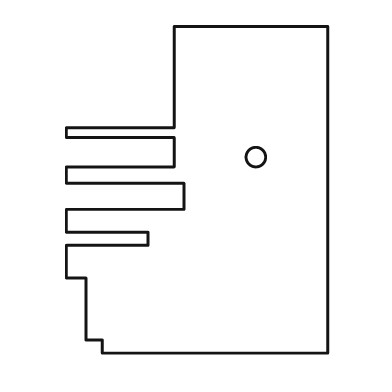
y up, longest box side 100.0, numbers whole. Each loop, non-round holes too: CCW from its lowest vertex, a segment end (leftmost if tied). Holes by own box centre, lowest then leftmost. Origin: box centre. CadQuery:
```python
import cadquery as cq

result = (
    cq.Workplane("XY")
    .moveTo(-29.0, -50.0)
    .lineTo(40.0, -50.0)
    .lineTo(40.0, 50.0)
    .lineTo(-7.0, 50.0)
    .lineTo(-7.0, 19.0)
    .lineTo(-40.0, 19.0)
    .lineTo(-40.0, 16.0)
    .lineTo(-7.0, 16.0)
    .lineTo(-7.0, 7.0)
    .lineTo(-40.0, 7.0)
    .lineTo(-40.0, 2.0)
    .lineTo(-4.0, 2.0)
    .lineTo(-4.0, -6.0)
    .lineTo(-40.0, -6.0)
    .lineTo(-40.0, -13.0)
    .lineTo(-15.0, -13.0)
    .lineTo(-15.0, -17.0)
    .lineTo(-40.0, -17.0)
    .lineTo(-40.0, -27.0)
    .lineTo(-34.0, -27.0)
    .lineTo(-34.0, -46.0)
    .lineTo(-29.0, -46.0)
    .close()
    .moveTo(18.0, 10.0)
    .circle(3.0)
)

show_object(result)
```